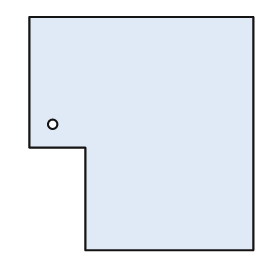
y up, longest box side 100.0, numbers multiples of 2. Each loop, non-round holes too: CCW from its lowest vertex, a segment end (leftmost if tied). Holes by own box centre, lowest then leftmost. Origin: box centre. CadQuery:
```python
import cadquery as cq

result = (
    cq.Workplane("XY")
    .moveTo(-24.0, -50.0)
    .lineTo(48.0, -50.0)
    .lineTo(48.0, 50.0)
    .lineTo(-48.0, 50.0)
    .lineTo(-48.0, -6.0)
    .lineTo(-24.0, -6.0)
    .close()
    .moveTo(-38.0, 4.0)
    .circle(2.0)
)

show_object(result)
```